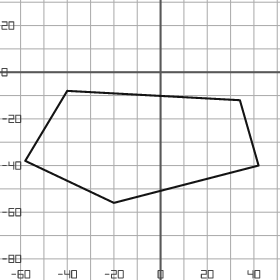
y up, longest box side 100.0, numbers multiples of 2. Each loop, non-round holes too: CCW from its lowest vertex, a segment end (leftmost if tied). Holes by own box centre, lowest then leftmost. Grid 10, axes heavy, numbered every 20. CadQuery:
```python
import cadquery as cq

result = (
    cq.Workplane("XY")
    .moveTo(-20.0, -56.0)
    .lineTo(42.0, -40.0)
    .lineTo(34.0, -12.0)
    .lineTo(-40.0, -8.0)
    .lineTo(-58.0, -38.0)
    .close()
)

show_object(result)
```